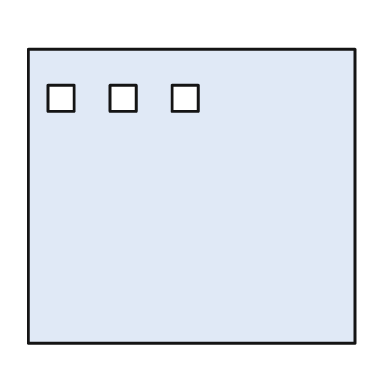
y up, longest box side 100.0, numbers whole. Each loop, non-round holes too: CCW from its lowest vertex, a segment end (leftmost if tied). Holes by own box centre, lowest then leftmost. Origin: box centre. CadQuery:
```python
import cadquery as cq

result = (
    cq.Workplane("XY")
    .moveTo(-50.0, -45.0)
    .lineTo(50.0, -45.0)
    .lineTo(50.0, 45.0)
    .lineTo(-50.0, 45.0)
    .close()
    .moveTo(-44.0, 26.0)
    .lineTo(-36.0, 26.0)
    .lineTo(-36.0, 34.0)
    .lineTo(-44.0, 34.0)
    .close()
    .moveTo(-25.0, 26.0)
    .lineTo(-17.0, 26.0)
    .lineTo(-17.0, 34.0)
    .lineTo(-25.0, 34.0)
    .close()
    .moveTo(-6.0, 26.0)
    .lineTo(2.0, 26.0)
    .lineTo(2.0, 34.0)
    .lineTo(-6.0, 34.0)
    .close()
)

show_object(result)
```